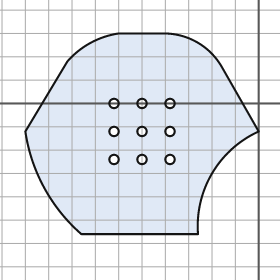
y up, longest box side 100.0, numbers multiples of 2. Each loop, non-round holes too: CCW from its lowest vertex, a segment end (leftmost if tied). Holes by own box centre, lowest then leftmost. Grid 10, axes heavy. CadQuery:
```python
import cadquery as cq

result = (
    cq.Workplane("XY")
    .moveTo(-76.0, -56.0)
    .lineTo(-26.0, -56.0)
    .threePointArc((-20.0, -30.0), (0.0, -12.0))
    .lineTo(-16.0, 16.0)
    .threePointArc((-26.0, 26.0), (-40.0, 30.0))
    .lineTo(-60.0, 30.0)
    .threePointArc((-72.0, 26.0), (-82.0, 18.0))
    .lineTo(-100.0, -12.0)
    .threePointArc((-92.0, -36.0), (-76.0, -56.0))
    .close()
    .moveTo(-62.0, -24.0)
    .circle(2.0)
    .moveTo(-50.0, -24.0)
    .circle(2.0)
    .moveTo(-38.0, -24.0)
    .circle(2.0)
    .moveTo(-62.0, -12.0)
    .circle(2.0)
    .moveTo(-50.0, -12.0)
    .circle(2.0)
    .moveTo(-38.0, -12.0)
    .circle(2.0)
    .moveTo(-62.0, 0.0)
    .circle(2.0)
    .moveTo(-50.0, 0.0)
    .circle(2.0)
    .moveTo(-38.0, 0.0)
    .circle(2.0)
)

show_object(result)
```